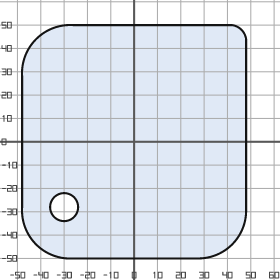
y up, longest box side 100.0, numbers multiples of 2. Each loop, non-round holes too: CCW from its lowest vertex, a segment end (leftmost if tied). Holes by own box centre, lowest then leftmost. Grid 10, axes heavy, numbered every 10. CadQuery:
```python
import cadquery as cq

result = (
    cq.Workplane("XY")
    .moveTo(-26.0, -50.0)
    .lineTo(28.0, -50.0)
    .threePointArc((42.0, -44.0), (48.0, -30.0))
    .lineTo(48.0, 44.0)
    .threePointArc((46.0, 48.0), (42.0, 50.0))
    .lineTo(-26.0, 50.0)
    .threePointArc((-42.0, 44.0), (-48.0, 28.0))
    .lineTo(-48.0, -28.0)
    .threePointArc((-42.0, -44.0), (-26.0, -50.0))
    .close()
    .moveTo(-30.0, -28.0)
    .circle(6.0)
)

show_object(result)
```